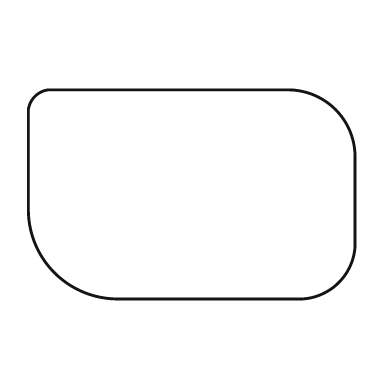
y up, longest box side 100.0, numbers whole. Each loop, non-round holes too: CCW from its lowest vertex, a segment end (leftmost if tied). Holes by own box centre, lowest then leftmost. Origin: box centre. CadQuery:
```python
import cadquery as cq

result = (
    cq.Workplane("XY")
    .moveTo(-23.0, -32.0)
    .lineTo(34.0, -32.0)
    .threePointArc((45.0, -27.0), (50.0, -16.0))
    .lineTo(50.0, 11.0)
    .threePointArc((44.0, 26.0), (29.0, 32.0))
    .lineTo(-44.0, 32.0)
    .threePointArc((-48.0, 30.0), (-50.0, 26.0))
    .lineTo(-50.0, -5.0)
    .threePointArc((-42.0, -24.0), (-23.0, -32.0))
    .close()
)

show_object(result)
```